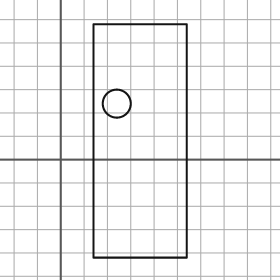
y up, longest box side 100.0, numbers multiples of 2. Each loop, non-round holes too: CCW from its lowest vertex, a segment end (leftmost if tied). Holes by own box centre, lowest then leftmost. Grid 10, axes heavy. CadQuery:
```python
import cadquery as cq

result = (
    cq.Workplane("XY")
    .moveTo(14.0, -42.0)
    .lineTo(54.0, -42.0)
    .lineTo(54.0, 58.0)
    .lineTo(14.0, 58.0)
    .close()
    .moveTo(24.0, 24.0)
    .circle(6.0)
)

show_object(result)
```